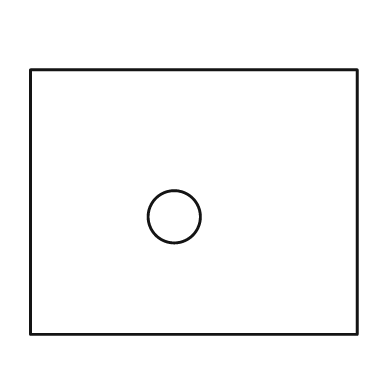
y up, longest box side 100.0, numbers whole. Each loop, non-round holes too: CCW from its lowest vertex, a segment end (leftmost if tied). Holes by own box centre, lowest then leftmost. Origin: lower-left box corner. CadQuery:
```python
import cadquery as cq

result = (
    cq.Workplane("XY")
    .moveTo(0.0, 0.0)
    .lineTo(100.0, 0.0)
    .lineTo(100.0, 81.0)
    .lineTo(0.0, 81.0)
    .close()
    .moveTo(44.0, 36.0)
    .circle(8.0)
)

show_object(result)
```